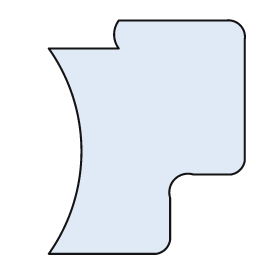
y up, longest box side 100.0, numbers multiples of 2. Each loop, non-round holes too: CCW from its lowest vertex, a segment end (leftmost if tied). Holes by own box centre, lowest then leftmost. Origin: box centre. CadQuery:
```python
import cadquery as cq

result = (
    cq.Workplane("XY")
    .moveTo(-42.0, -50.0)
    .lineTo(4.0, -50.0)
    .threePointArc((8.0, -48.0), (10.0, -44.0))
    .lineTo(10.0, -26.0)
    .threePointArc((12.0, -18.0), (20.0, -16.0))
    .lineTo(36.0, -16.0)
    .threePointArc((40.0, -14.0), (42.0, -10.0))
    .lineTo(42.0, 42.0)
    .threePointArc((40.0, 48.0), (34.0, 50.0))
    .lineTo(-12.0, 50.0)
    .threePointArc((-14.0, 44.0), (-12.0, 38.0))
    .lineTo(-42.0, 38.0)
    .threePointArc((-28.0, -6.0), (-42.0, -50.0))
    .close()
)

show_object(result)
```